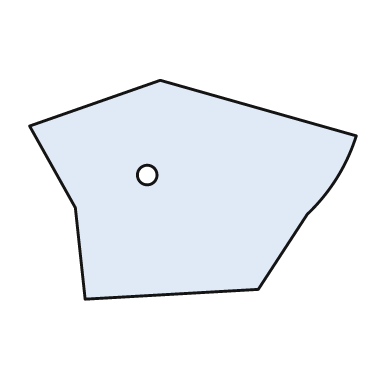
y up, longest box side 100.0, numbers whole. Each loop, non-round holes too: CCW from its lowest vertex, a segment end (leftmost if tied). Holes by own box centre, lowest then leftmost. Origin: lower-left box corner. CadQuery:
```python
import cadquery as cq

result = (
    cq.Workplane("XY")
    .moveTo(17.0, 0.0)
    .lineTo(70.0, 3.0)
    .lineTo(85.0, 26.0)
    .threePointArc((94.0, 37.0), (100.0, 50.0))
    .lineTo(40.0, 67.0)
    .lineTo(0.0, 53.0)
    .lineTo(14.0, 28.0)
    .close()
    .moveTo(36.0, 38.0)
    .circle(3.0)
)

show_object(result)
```